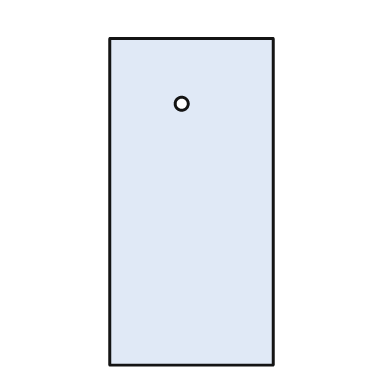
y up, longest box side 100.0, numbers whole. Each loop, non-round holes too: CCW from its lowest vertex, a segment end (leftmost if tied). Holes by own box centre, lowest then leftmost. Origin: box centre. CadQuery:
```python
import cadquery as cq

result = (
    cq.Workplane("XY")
    .moveTo(-25.0, -50.0)
    .lineTo(25.0, -50.0)
    .lineTo(25.0, 50.0)
    .lineTo(-25.0, 50.0)
    .close()
    .moveTo(-3.0, 30.0)
    .circle(2.0)
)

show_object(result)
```